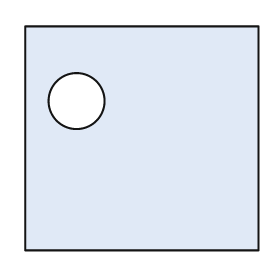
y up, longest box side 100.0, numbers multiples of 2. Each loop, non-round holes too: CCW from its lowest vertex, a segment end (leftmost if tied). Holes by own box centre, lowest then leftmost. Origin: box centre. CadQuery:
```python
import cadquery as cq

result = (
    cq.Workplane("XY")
    .moveTo(-50.0, -48.0)
    .lineTo(50.0, -48.0)
    .lineTo(50.0, 48.0)
    .lineTo(-50.0, 48.0)
    .close()
    .moveTo(-28.0, 16.0)
    .circle(12.0)
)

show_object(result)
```